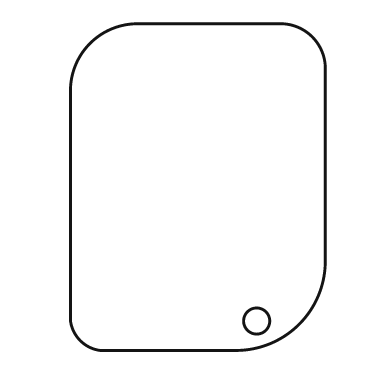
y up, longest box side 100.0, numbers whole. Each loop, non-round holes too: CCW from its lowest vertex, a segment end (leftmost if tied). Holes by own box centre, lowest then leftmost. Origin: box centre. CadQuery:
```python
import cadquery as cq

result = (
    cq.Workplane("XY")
    .moveTo(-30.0, -50.0)
    .lineTo(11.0, -50.0)
    .threePointArc((31.0, -42.0), (39.0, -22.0))
    .lineTo(39.0, 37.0)
    .threePointArc((35.0, 46.0), (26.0, 50.0))
    .lineTo(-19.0, 50.0)
    .threePointArc((-33.0, 44.0), (-39.0, 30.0))
    .lineTo(-39.0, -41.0)
    .threePointArc((-36.0, -47.0), (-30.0, -50.0))
    .close()
    .moveTo(18.0, -41.0)
    .circle(4.0)
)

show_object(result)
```